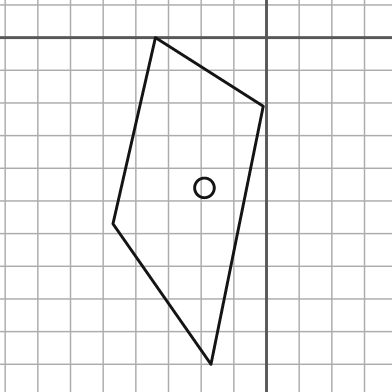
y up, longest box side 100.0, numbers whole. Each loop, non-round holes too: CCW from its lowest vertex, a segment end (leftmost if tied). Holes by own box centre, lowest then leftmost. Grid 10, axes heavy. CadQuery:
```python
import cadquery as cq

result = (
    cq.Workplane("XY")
    .moveTo(-17.0, -100.0)
    .lineTo(-1.0, -21.0)
    .lineTo(-34.0, 0.0)
    .lineTo(-47.0, -57.0)
    .close()
    .moveTo(-19.0, -46.0)
    .circle(3.0)
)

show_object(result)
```